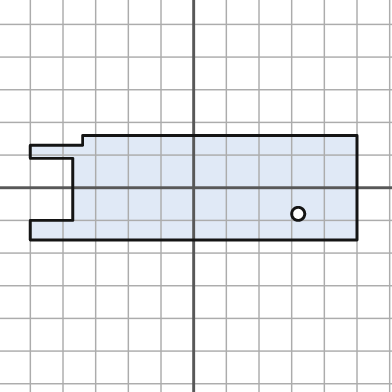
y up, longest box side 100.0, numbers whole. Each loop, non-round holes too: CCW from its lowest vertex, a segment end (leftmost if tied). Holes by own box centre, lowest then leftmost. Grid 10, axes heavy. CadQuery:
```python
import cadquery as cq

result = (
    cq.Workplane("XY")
    .moveTo(-50.0, -16.0)
    .lineTo(50.0, -16.0)
    .lineTo(50.0, 16.0)
    .lineTo(-34.0, 16.0)
    .lineTo(-34.0, 13.0)
    .lineTo(-50.0, 13.0)
    .lineTo(-50.0, 9.0)
    .lineTo(-37.0, 9.0)
    .lineTo(-37.0, -10.0)
    .lineTo(-50.0, -10.0)
    .close()
    .moveTo(32.0, -8.0)
    .circle(2.0)
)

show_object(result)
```